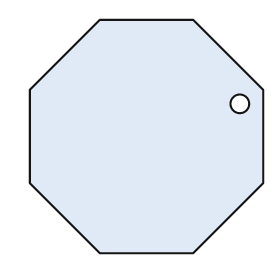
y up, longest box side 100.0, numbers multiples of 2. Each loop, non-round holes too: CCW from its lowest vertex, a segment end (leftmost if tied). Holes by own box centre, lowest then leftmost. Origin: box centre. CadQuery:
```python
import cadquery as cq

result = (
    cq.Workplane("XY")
    .moveTo(-20.0, -50.0)
    .lineTo(20.0, -50.0)
    .lineTo(50.0, -20.0)
    .lineTo(50.0, 20.0)
    .lineTo(20.0, 50.0)
    .lineTo(-20.0, 50.0)
    .lineTo(-50.0, 20.0)
    .lineTo(-50.0, -20.0)
    .close()
    .moveTo(40.0, 14.0)
    .circle(4.0)
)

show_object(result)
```